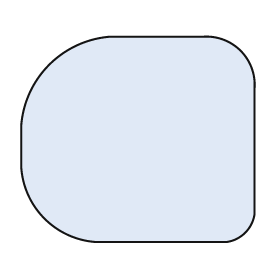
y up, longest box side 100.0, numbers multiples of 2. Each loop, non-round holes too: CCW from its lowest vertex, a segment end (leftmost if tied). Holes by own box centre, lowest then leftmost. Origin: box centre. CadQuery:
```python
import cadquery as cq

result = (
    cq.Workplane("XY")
    .moveTo(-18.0, -44.0)
    .lineTo(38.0, -44.0)
    .threePointArc((46.0, -40.0), (50.0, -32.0))
    .lineTo(50.0, 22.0)
    .threePointArc((44.0, 38.0), (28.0, 44.0))
    .lineTo(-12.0, 44.0)
    .threePointArc((-38.0, 32.0), (-50.0, 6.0))
    .lineTo(-50.0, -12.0)
    .threePointArc((-40.0, -34.0), (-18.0, -44.0))
    .close()
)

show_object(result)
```